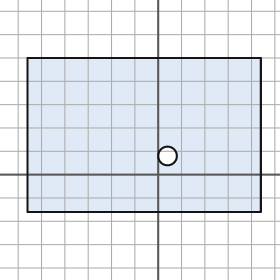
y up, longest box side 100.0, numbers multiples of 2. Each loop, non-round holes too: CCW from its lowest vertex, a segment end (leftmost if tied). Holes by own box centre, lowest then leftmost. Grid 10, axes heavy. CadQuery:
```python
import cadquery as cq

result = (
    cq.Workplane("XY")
    .moveTo(-56.0, -16.0)
    .lineTo(44.0, -16.0)
    .lineTo(44.0, 50.0)
    .lineTo(-56.0, 50.0)
    .close()
    .moveTo(4.0, 8.0)
    .circle(4.0)
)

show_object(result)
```